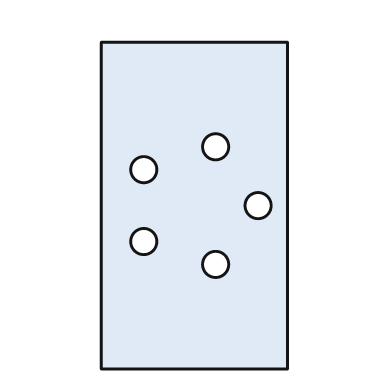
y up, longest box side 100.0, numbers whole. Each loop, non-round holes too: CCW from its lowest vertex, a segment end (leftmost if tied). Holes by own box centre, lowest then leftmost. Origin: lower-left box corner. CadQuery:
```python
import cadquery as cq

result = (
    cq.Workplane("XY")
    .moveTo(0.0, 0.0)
    .lineTo(57.0, 0.0)
    .lineTo(57.0, 100.0)
    .lineTo(0.0, 100.0)
    .close()
    .moveTo(35.0, 32.0)
    .circle(4.0)
    .moveTo(13.0, 39.0)
    .circle(4.0)
    .moveTo(48.0, 50.0)
    .circle(4.0)
    .moveTo(13.0, 61.0)
    .circle(4.0)
    .moveTo(35.0, 68.0)
    .circle(4.0)
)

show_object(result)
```